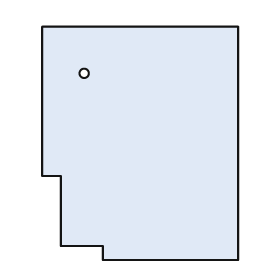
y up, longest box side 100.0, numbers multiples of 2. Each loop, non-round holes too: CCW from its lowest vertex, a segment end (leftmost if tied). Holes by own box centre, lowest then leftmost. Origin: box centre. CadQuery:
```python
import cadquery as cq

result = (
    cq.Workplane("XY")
    .moveTo(-16.0, -50.0)
    .lineTo(42.0, -50.0)
    .lineTo(42.0, 50.0)
    .lineTo(-42.0, 50.0)
    .lineTo(-42.0, -14.0)
    .lineTo(-34.0, -14.0)
    .lineTo(-34.0, -44.0)
    .lineTo(-16.0, -44.0)
    .close()
    .moveTo(-24.0, 30.0)
    .circle(2.0)
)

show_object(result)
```